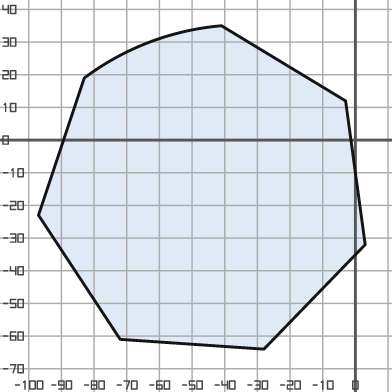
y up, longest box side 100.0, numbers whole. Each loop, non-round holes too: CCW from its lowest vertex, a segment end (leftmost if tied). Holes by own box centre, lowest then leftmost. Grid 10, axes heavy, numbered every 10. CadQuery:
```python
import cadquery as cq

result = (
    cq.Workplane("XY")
    .moveTo(-28.0, -64.0)
    .lineTo(3.0, -32.0)
    .lineTo(-3.0, 12.0)
    .lineTo(-41.0, 35.0)
    .threePointArc((-63.0, 30.0), (-83.0, 19.0))
    .lineTo(-97.0, -23.0)
    .lineTo(-72.0, -61.0)
    .close()
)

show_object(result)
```